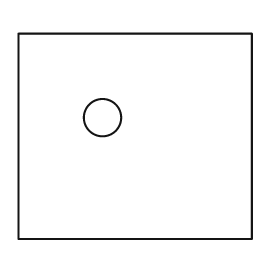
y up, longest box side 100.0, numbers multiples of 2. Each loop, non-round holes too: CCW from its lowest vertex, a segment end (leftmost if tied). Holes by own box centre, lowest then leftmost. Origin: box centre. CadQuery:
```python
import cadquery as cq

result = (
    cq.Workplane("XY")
    .moveTo(-50.0, -44.0)
    .lineTo(50.0, -44.0)
    .lineTo(50.0, 44.0)
    .lineTo(-50.0, 44.0)
    .close()
    .moveTo(-14.0, 8.0)
    .circle(8.0)
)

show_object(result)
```